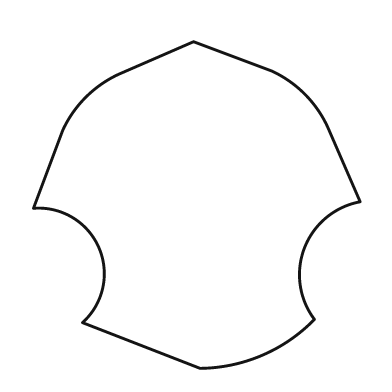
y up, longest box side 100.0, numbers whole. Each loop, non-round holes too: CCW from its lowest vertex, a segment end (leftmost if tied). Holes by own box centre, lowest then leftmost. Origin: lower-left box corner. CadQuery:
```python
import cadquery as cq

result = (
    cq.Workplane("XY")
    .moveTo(51.0, 0.0)
    .threePointArc((70.0, 4.0), (86.0, 15.0))
    .threePointArc((83.0, 37.0), (100.0, 51.0))
    .lineTo(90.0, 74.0)
    .threePointArc((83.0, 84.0), (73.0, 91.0))
    .lineTo(49.0, 100.0)
    .lineTo(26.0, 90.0)
    .threePointArc((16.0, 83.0), (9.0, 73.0))
    .lineTo(0.0, 49.0)
    .threePointArc((20.0, 37.0), (15.0, 14.0))
    .close()
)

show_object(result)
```